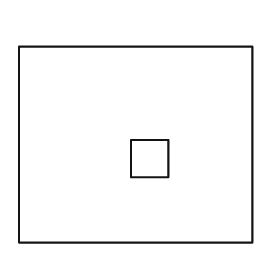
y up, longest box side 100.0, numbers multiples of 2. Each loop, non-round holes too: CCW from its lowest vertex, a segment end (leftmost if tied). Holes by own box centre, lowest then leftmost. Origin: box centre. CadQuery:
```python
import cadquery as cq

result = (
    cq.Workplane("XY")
    .moveTo(-50.0, -42.0)
    .lineTo(50.0, -42.0)
    .lineTo(50.0, 42.0)
    .lineTo(-50.0, 42.0)
    .close()
    .moveTo(-2.0, -14.0)
    .lineTo(14.0, -14.0)
    .lineTo(14.0, 2.0)
    .lineTo(-2.0, 2.0)
    .close()
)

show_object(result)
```